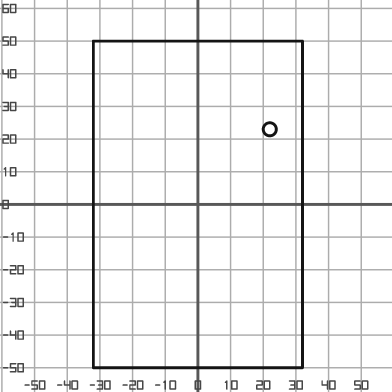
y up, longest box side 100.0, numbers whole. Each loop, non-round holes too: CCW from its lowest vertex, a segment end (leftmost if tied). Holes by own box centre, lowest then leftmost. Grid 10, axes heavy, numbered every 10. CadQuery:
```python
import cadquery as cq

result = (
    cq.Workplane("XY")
    .moveTo(-32.0, -50.0)
    .lineTo(32.0, -50.0)
    .lineTo(32.0, 50.0)
    .lineTo(-32.0, 50.0)
    .close()
    .moveTo(22.0, 23.0)
    .circle(2.0)
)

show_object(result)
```